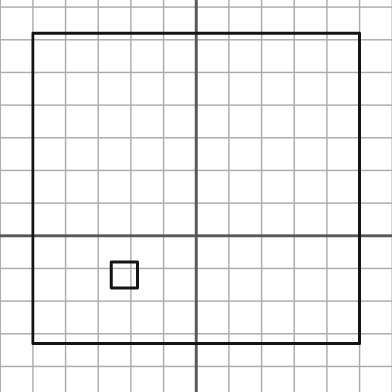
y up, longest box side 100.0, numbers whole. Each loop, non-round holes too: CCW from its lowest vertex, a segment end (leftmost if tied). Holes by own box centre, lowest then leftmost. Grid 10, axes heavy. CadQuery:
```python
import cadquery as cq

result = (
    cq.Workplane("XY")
    .moveTo(-50.0, -33.0)
    .lineTo(50.0, -33.0)
    .lineTo(50.0, 62.0)
    .lineTo(-50.0, 62.0)
    .close()
    .moveTo(-26.0, -16.0)
    .lineTo(-18.0, -16.0)
    .lineTo(-18.0, -8.0)
    .lineTo(-26.0, -8.0)
    .close()
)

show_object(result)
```